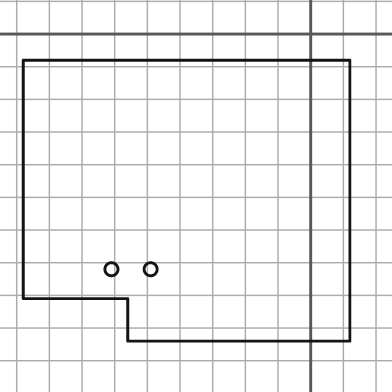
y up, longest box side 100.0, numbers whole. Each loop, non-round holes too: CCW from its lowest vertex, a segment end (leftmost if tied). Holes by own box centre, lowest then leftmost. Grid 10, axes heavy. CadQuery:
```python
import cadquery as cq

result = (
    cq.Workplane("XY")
    .moveTo(-56.0, -94.0)
    .lineTo(12.0, -94.0)
    .lineTo(12.0, -8.0)
    .lineTo(-88.0, -8.0)
    .lineTo(-88.0, -81.0)
    .lineTo(-56.0, -81.0)
    .close()
    .moveTo(-61.0, -72.0)
    .circle(2.0)
    .moveTo(-49.0, -72.0)
    .circle(2.0)
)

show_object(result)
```